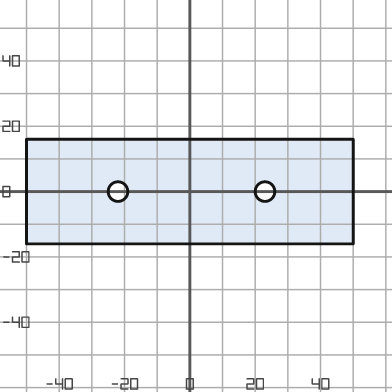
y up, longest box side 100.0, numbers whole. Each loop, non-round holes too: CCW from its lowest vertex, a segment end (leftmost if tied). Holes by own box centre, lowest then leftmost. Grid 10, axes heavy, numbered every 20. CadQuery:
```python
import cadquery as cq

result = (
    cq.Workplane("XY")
    .moveTo(-50.0, -16.0)
    .lineTo(50.0, -16.0)
    .lineTo(50.0, 16.0)
    .lineTo(-50.0, 16.0)
    .close()
    .moveTo(-22.0, 0.0)
    .circle(3.0)
    .moveTo(23.0, 0.0)
    .circle(3.0)
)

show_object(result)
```